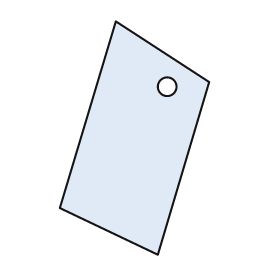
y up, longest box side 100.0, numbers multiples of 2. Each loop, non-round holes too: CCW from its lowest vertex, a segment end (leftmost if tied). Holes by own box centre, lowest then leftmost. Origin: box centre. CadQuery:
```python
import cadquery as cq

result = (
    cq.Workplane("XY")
    .moveTo(10.0, -50.0)
    .lineTo(32.0, 24.0)
    .lineTo(-8.0, 50.0)
    .lineTo(-32.0, -30.0)
    .close()
    .moveTo(14.0, 22.0)
    .circle(4.0)
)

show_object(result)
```